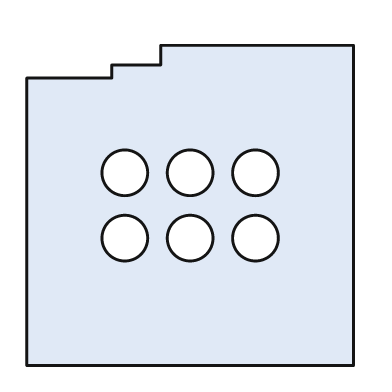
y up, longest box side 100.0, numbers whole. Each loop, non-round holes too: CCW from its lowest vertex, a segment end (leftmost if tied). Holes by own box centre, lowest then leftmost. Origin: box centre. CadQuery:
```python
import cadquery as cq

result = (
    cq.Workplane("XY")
    .moveTo(-50.0, -49.0)
    .lineTo(50.0, -49.0)
    .lineTo(50.0, 49.0)
    .lineTo(-9.0, 49.0)
    .lineTo(-9.0, 43.0)
    .lineTo(-24.0, 43.0)
    .lineTo(-24.0, 39.0)
    .lineTo(-50.0, 39.0)
    .close()
    .moveTo(-20.0, -10.0)
    .circle(7.0)
    .moveTo(0.0, -10.0)
    .circle(7.0)
    .moveTo(20.0, -10.0)
    .circle(7.0)
    .moveTo(-20.0, 10.0)
    .circle(7.0)
    .moveTo(0.0, 10.0)
    .circle(7.0)
    .moveTo(20.0, 10.0)
    .circle(7.0)
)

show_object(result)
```